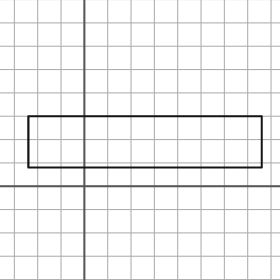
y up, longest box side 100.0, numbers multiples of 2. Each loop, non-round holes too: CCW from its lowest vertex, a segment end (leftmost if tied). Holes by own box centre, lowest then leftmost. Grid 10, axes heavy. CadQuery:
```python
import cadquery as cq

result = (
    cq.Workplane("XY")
    .moveTo(-24.0, 8.0)
    .lineTo(76.0, 8.0)
    .lineTo(76.0, 30.0)
    .lineTo(-24.0, 30.0)
    .close()
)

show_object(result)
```